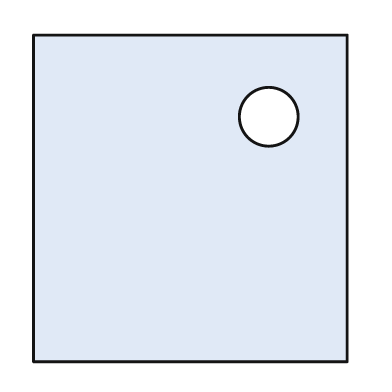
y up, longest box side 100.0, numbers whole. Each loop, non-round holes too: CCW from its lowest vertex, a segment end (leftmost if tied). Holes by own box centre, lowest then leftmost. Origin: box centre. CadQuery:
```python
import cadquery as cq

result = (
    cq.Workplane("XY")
    .moveTo(-48.0, -50.0)
    .lineTo(48.0, -50.0)
    .lineTo(48.0, 50.0)
    .lineTo(-48.0, 50.0)
    .close()
    .moveTo(24.0, 25.0)
    .circle(9.0)
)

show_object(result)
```